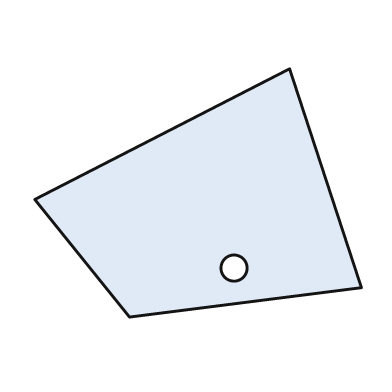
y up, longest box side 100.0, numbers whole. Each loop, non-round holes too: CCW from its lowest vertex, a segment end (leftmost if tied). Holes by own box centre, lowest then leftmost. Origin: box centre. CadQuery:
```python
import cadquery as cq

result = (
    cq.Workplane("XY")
    .moveTo(-21.0, -38.0)
    .lineTo(50.0, -29.0)
    .lineTo(28.0, 38.0)
    .lineTo(-50.0, -2.0)
    .close()
    .moveTo(11.0, -23.0)
    .circle(4.0)
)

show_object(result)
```